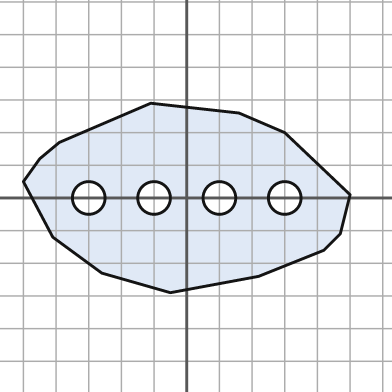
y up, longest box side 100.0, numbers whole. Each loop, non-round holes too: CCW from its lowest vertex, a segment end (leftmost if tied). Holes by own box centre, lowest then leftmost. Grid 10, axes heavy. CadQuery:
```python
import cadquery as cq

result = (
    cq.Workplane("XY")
    .moveTo(-5.0, -29.0)
    .lineTo(22.0, -24.0)
    .lineTo(42.0, -16.0)
    .lineTo(47.0, -11.0)
    .lineTo(50.0, 1.0)
    .lineTo(30.0, 20.0)
    .lineTo(16.0, 26.0)
    .lineTo(-11.0, 29.0)
    .lineTo(-39.0, 17.0)
    .lineTo(-45.0, 12.0)
    .lineTo(-50.0, 5.0)
    .lineTo(-41.0, -12.0)
    .lineTo(-26.0, -23.0)
    .close()
    .moveTo(-30.0, 0.0)
    .circle(5.0)
    .moveTo(-10.0, 0.0)
    .circle(5.0)
    .moveTo(10.0, 0.0)
    .circle(5.0)
    .moveTo(30.0, 0.0)
    .circle(5.0)
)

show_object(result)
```